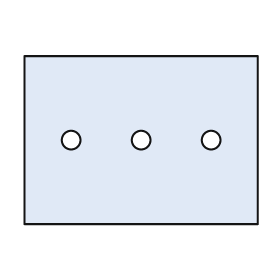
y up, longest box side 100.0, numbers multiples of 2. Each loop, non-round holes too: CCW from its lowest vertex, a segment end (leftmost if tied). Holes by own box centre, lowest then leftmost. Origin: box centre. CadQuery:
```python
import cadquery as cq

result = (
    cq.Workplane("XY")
    .moveTo(-50.0, -36.0)
    .lineTo(50.0, -36.0)
    .lineTo(50.0, 36.0)
    .lineTo(-50.0, 36.0)
    .close()
    .moveTo(-30.0, 0.0)
    .circle(4.0)
    .moveTo(0.0, 0.0)
    .circle(4.0)
    .moveTo(30.0, 0.0)
    .circle(4.0)
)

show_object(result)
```